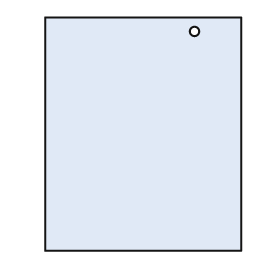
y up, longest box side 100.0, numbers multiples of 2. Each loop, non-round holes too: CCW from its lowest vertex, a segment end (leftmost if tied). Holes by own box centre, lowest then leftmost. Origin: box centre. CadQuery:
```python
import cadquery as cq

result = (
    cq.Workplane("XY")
    .moveTo(-42.0, -50.0)
    .lineTo(42.0, -50.0)
    .lineTo(42.0, 50.0)
    .lineTo(-42.0, 50.0)
    .close()
    .moveTo(22.0, 44.0)
    .circle(2.0)
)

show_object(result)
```